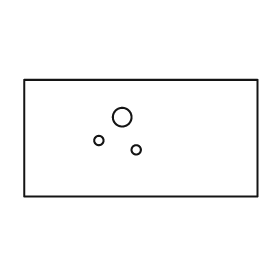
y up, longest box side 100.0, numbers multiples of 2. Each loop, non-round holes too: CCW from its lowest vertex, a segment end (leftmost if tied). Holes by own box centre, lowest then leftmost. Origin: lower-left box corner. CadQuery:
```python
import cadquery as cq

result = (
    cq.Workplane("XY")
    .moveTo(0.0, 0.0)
    .lineTo(100.0, 0.0)
    .lineTo(100.0, 50.0)
    .lineTo(0.0, 50.0)
    .close()
    .moveTo(48.0, 20.0)
    .circle(2.0)
    .moveTo(32.0, 24.0)
    .circle(2.0)
    .moveTo(42.0, 34.0)
    .circle(4.0)
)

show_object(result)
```